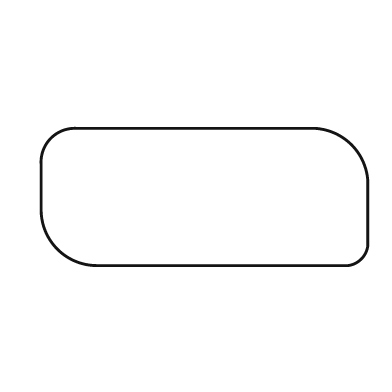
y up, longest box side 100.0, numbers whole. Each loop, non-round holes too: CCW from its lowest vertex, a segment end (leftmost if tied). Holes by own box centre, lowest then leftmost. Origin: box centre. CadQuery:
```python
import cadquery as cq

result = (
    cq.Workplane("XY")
    .moveTo(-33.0, -21.0)
    .lineTo(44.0, -21.0)
    .threePointArc((48.0, -19.0), (50.0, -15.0))
    .lineTo(50.0, 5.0)
    .threePointArc((45.0, 16.0), (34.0, 21.0))
    .lineTo(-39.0, 21.0)
    .threePointArc((-47.0, 18.0), (-50.0, 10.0))
    .lineTo(-50.0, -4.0)
    .threePointArc((-45.0, -16.0), (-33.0, -21.0))
    .close()
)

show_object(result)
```